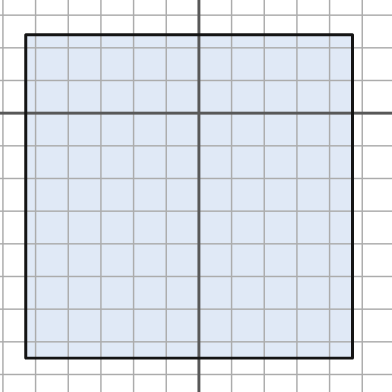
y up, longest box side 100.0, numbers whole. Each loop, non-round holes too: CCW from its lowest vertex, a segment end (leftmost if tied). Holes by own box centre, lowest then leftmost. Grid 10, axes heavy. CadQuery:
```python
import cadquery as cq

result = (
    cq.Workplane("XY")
    .moveTo(-53.0, -75.0)
    .lineTo(47.0, -75.0)
    .lineTo(47.0, 24.0)
    .lineTo(-53.0, 24.0)
    .close()
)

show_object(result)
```